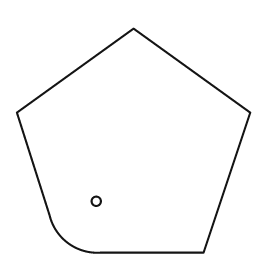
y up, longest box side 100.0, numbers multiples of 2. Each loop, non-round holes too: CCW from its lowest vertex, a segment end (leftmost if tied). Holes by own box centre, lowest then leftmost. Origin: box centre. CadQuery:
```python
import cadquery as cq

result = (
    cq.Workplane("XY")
    .moveTo(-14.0, -48.0)
    .lineTo(30.0, -48.0)
    .lineTo(50.0, 12.0)
    .lineTo(0.0, 48.0)
    .lineTo(-50.0, 12.0)
    .lineTo(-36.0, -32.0)
    .threePointArc((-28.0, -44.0), (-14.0, -48.0))
    .close()
    .moveTo(-16.0, -26.0)
    .circle(2.0)
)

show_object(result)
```